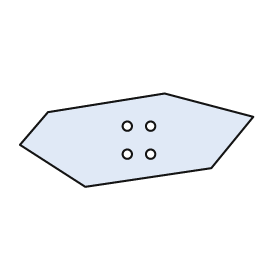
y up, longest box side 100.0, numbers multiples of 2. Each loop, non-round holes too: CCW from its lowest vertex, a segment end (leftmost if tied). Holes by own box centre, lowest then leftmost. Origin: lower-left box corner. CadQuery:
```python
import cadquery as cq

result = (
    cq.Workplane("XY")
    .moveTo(28.0, 0.0)
    .lineTo(82.0, 8.0)
    .lineTo(100.0, 30.0)
    .lineTo(62.0, 40.0)
    .lineTo(12.0, 32.0)
    .lineTo(0.0, 18.0)
    .close()
    .moveTo(46.0, 14.0)
    .circle(2.0)
    .moveTo(56.0, 14.0)
    .circle(2.0)
    .moveTo(46.0, 26.0)
    .circle(2.0)
    .moveTo(56.0, 26.0)
    .circle(2.0)
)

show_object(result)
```